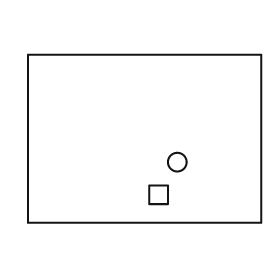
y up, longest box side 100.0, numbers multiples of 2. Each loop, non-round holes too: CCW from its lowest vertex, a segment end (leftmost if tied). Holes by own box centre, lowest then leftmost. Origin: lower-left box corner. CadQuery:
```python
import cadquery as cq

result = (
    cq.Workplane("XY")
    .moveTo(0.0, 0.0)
    .lineTo(100.0, 0.0)
    .lineTo(100.0, 72.0)
    .lineTo(0.0, 72.0)
    .close()
    .moveTo(52.0, 8.0)
    .lineTo(60.0, 8.0)
    .lineTo(60.0, 16.0)
    .lineTo(52.0, 16.0)
    .close()
    .moveTo(64.0, 26.0)
    .circle(4.0)
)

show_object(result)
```